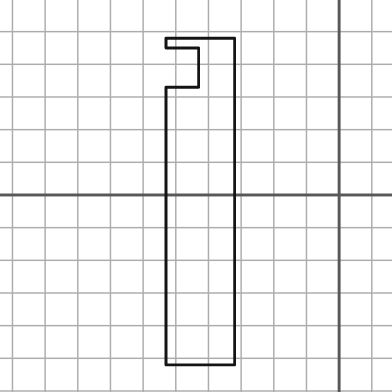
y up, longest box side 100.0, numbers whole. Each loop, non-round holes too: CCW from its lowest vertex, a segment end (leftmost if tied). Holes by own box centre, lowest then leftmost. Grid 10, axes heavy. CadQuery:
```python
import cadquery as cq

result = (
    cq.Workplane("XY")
    .moveTo(-53.0, -52.0)
    .lineTo(-32.0, -52.0)
    .lineTo(-32.0, 48.0)
    .lineTo(-53.0, 48.0)
    .lineTo(-53.0, 45.0)
    .lineTo(-43.0, 45.0)
    .lineTo(-43.0, 33.0)
    .lineTo(-53.0, 33.0)
    .close()
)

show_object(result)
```